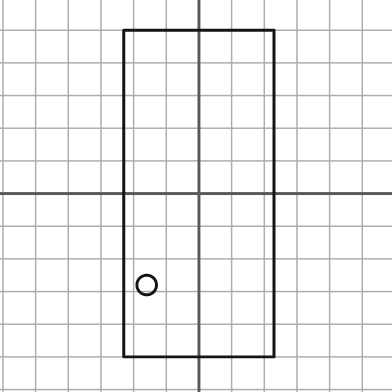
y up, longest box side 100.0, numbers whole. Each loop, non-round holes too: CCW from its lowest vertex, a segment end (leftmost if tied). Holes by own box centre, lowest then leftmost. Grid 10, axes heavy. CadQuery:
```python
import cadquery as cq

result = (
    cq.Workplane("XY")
    .moveTo(-23.0, -50.0)
    .lineTo(23.0, -50.0)
    .lineTo(23.0, 50.0)
    .lineTo(-23.0, 50.0)
    .close()
    .moveTo(-16.0, -28.0)
    .circle(3.0)
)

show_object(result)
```